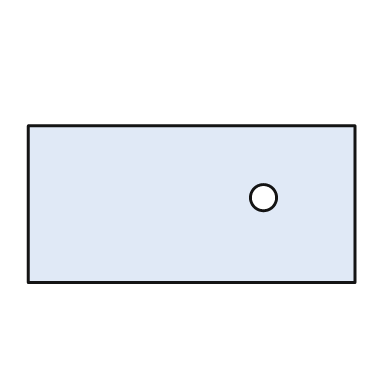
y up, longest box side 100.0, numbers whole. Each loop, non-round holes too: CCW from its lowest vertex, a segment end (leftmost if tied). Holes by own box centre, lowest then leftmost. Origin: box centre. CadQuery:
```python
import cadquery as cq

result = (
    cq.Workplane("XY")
    .moveTo(-50.0, -24.0)
    .lineTo(50.0, -24.0)
    .lineTo(50.0, 24.0)
    .lineTo(-50.0, 24.0)
    .close()
    .moveTo(22.0, 2.0)
    .circle(4.0)
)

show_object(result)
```